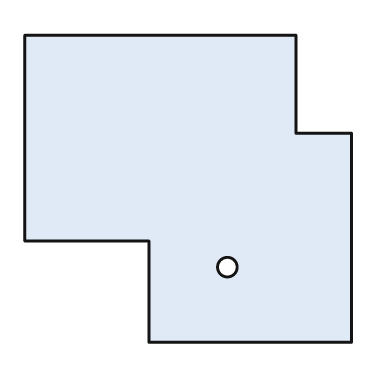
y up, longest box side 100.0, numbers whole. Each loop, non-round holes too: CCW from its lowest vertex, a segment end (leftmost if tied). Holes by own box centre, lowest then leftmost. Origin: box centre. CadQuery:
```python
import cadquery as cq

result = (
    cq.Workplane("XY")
    .moveTo(-12.0, -47.0)
    .lineTo(50.0, -47.0)
    .lineTo(50.0, 17.0)
    .lineTo(33.0, 17.0)
    .lineTo(33.0, 47.0)
    .lineTo(-50.0, 47.0)
    .lineTo(-50.0, -16.0)
    .lineTo(-12.0, -16.0)
    .close()
    .moveTo(12.0, -24.0)
    .circle(3.0)
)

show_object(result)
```